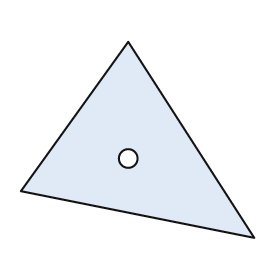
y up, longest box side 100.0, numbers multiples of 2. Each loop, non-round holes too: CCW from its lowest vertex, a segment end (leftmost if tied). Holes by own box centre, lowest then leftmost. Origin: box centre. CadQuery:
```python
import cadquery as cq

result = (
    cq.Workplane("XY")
    .moveTo(50.0, -42.0)
    .lineTo(-4.0, 42.0)
    .lineTo(-50.0, -22.0)
    .close()
    .moveTo(-4.0, -8.0)
    .circle(4.0)
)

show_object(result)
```